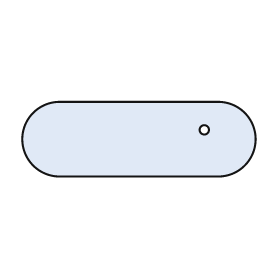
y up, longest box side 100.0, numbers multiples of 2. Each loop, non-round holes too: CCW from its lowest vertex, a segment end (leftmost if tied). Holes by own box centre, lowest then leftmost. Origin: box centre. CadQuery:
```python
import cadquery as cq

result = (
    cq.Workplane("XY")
    .moveTo(-34.0, -16.0)
    .lineTo(34.0, -16.0)
    .threePointArc((50.0, 0.0), (34.0, 16.0))
    .lineTo(-34.0, 16.0)
    .threePointArc((-50.0, 0.0), (-34.0, -16.0))
    .close()
    .moveTo(28.0, 4.0)
    .circle(2.0)
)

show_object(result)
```